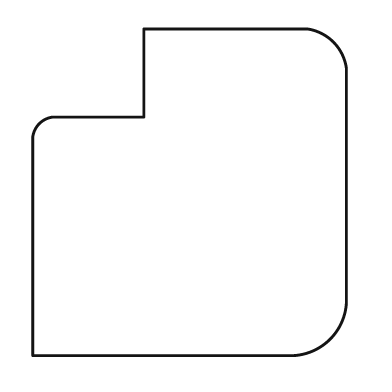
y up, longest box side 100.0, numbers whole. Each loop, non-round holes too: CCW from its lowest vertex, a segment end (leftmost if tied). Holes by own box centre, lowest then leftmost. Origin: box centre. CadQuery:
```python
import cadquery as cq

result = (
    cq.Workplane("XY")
    .moveTo(-48.0, -50.0)
    .lineTo(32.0, -50.0)
    .threePointArc((43.0, -45.0), (48.0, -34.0))
    .lineTo(48.0, 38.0)
    .threePointArc((44.0, 46.0), (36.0, 50.0))
    .lineTo(-14.0, 50.0)
    .lineTo(-14.0, 23.0)
    .lineTo(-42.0, 23.0)
    .threePointArc((-46.0, 21.0), (-48.0, 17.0))
    .close()
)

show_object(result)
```